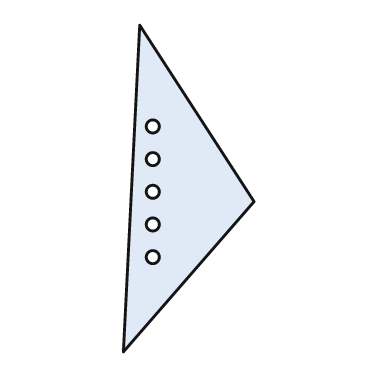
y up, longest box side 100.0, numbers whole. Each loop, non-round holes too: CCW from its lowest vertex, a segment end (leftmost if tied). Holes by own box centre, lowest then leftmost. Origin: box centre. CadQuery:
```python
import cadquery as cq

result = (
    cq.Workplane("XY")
    .moveTo(-20.0, -50.0)
    .lineTo(20.0, -4.0)
    .lineTo(-15.0, 50.0)
    .close()
    .moveTo(-11.0, -21.0)
    .circle(2.0)
    .moveTo(-11.0, -11.0)
    .circle(2.0)
    .moveTo(-11.0, -1.0)
    .circle(2.0)
    .moveTo(-11.0, 9.0)
    .circle(2.0)
    .moveTo(-11.0, 19.0)
    .circle(2.0)
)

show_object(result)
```